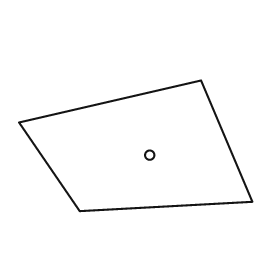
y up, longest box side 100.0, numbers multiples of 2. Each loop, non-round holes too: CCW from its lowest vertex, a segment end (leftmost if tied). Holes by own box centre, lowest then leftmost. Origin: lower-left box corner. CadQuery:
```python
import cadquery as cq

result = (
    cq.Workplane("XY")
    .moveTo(26.0, 0.0)
    .lineTo(100.0, 4.0)
    .lineTo(78.0, 56.0)
    .lineTo(0.0, 38.0)
    .close()
    .moveTo(56.0, 24.0)
    .circle(2.0)
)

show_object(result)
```